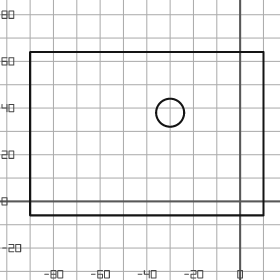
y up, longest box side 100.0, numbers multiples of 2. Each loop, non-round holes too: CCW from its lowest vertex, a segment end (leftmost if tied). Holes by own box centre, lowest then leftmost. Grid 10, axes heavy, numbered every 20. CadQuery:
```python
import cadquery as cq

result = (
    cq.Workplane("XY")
    .moveTo(-90.0, -6.0)
    .lineTo(10.0, -6.0)
    .lineTo(10.0, 64.0)
    .lineTo(-90.0, 64.0)
    .close()
    .moveTo(-30.0, 38.0)
    .circle(6.0)
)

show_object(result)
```